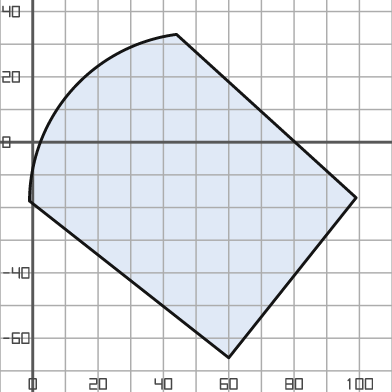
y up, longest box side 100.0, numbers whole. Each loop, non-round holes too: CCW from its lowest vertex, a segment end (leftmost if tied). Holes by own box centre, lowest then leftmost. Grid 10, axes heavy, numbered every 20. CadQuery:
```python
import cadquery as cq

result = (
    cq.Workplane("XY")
    .moveTo(60.0, -66.0)
    .lineTo(99.0, -17.0)
    .lineTo(44.0, 33.0)
    .threePointArc((12.0, 16.0), (-1.0, -18.0))
    .close()
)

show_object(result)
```